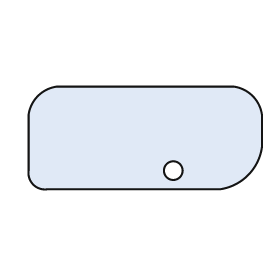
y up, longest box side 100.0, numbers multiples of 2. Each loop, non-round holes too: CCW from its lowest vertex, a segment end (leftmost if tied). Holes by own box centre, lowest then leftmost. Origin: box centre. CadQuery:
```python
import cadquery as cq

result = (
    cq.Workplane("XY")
    .moveTo(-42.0, -22.0)
    .lineTo(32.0, -22.0)
    .threePointArc((44.0, -16.0), (50.0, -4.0))
    .lineTo(50.0, 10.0)
    .threePointArc((46.0, 18.0), (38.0, 22.0))
    .lineTo(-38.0, 22.0)
    .threePointArc((-46.0, 18.0), (-50.0, 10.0))
    .lineTo(-50.0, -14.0)
    .threePointArc((-48.0, -20.0), (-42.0, -22.0))
    .close()
    .moveTo(12.0, -14.0)
    .circle(4.0)
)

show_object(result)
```